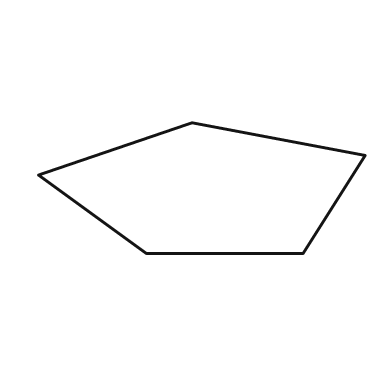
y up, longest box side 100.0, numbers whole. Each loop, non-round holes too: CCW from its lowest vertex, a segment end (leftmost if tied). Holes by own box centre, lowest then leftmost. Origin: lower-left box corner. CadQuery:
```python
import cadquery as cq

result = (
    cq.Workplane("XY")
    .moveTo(33.0, 0.0)
    .lineTo(81.0, 0.0)
    .lineTo(100.0, 30.0)
    .lineTo(47.0, 40.0)
    .lineTo(0.0, 24.0)
    .close()
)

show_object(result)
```